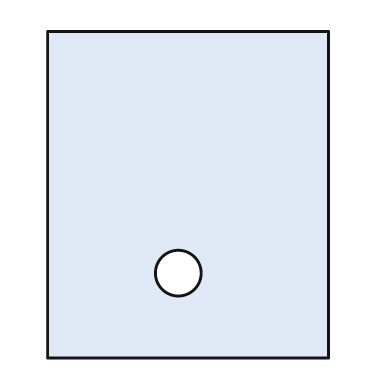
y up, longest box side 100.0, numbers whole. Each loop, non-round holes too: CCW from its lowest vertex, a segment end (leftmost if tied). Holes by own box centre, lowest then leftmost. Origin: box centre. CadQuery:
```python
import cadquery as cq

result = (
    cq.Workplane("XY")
    .moveTo(-43.0, -50.0)
    .lineTo(43.0, -50.0)
    .lineTo(43.0, 50.0)
    .lineTo(-43.0, 50.0)
    .close()
    .moveTo(-3.0, -24.0)
    .circle(7.0)
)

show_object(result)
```